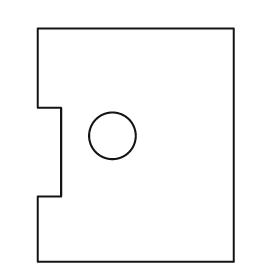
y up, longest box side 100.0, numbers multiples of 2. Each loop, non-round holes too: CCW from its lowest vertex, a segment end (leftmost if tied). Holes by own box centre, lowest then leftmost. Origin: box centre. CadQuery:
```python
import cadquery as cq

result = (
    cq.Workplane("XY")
    .moveTo(-42.0, -50.0)
    .lineTo(42.0, -50.0)
    .lineTo(42.0, 50.0)
    .lineTo(-42.0, 50.0)
    .lineTo(-42.0, 16.0)
    .lineTo(-32.0, 16.0)
    .lineTo(-32.0, -22.0)
    .lineTo(-42.0, -22.0)
    .close()
    .moveTo(-10.0, 4.0)
    .circle(10.0)
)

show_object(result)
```